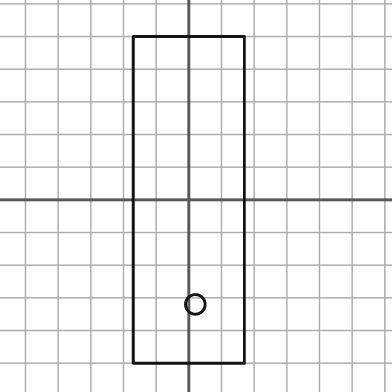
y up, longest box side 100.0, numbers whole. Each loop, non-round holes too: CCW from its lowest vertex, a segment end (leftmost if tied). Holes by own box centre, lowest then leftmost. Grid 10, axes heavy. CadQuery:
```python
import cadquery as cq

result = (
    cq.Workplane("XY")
    .moveTo(-17.0, -50.0)
    .lineTo(17.0, -50.0)
    .lineTo(17.0, 50.0)
    .lineTo(-17.0, 50.0)
    .close()
    .moveTo(2.0, -32.0)
    .circle(3.0)
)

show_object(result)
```